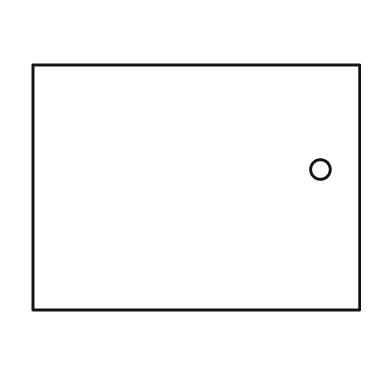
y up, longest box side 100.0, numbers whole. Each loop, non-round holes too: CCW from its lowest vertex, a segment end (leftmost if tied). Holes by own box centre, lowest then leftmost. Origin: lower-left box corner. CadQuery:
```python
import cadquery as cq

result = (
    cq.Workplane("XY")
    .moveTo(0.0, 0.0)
    .lineTo(100.0, 0.0)
    .lineTo(100.0, 75.0)
    .lineTo(0.0, 75.0)
    .close()
    .moveTo(88.0, 43.0)
    .circle(3.0)
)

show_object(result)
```